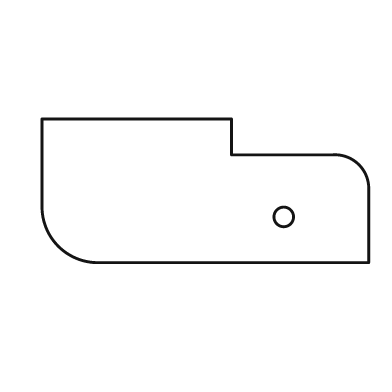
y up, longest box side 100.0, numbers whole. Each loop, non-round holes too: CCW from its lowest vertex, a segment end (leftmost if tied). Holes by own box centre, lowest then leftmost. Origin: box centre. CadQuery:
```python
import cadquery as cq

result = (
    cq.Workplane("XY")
    .moveTo(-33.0, -22.0)
    .lineTo(50.0, -22.0)
    .lineTo(50.0, 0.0)
    .threePointArc((47.0, 8.0), (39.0, 11.0))
    .lineTo(8.0, 11.0)
    .lineTo(8.0, 22.0)
    .lineTo(-50.0, 22.0)
    .lineTo(-50.0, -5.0)
    .threePointArc((-45.0, -17.0), (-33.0, -22.0))
    .close()
    .moveTo(24.0, -8.0)
    .circle(3.0)
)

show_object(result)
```